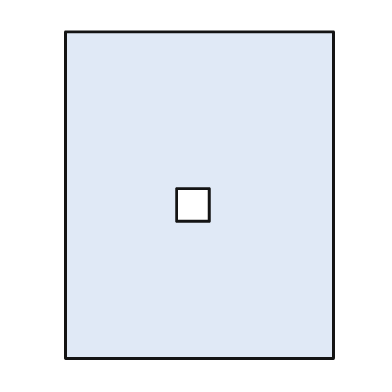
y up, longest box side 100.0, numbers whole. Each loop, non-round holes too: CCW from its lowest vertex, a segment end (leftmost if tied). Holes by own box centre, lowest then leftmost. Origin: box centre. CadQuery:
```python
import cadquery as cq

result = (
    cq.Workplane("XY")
    .moveTo(-41.0, -50.0)
    .lineTo(41.0, -50.0)
    .lineTo(41.0, 50.0)
    .lineTo(-41.0, 50.0)
    .close()
    .moveTo(-7.0, -8.0)
    .lineTo(3.0, -8.0)
    .lineTo(3.0, 2.0)
    .lineTo(-7.0, 2.0)
    .close()
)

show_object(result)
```